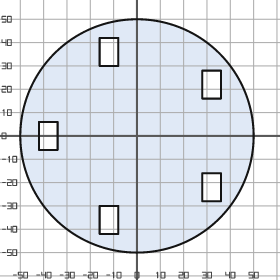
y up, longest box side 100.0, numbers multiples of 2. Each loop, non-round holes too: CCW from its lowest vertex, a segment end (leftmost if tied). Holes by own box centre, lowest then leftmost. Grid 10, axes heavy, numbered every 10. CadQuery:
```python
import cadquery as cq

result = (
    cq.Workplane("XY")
    .moveTo(0.0, 0.0)
    .circle(50.0)
    .moveTo(-16.0, -42.0)
    .lineTo(-8.0, -42.0)
    .lineTo(-8.0, -30.0)
    .lineTo(-16.0, -30.0)
    .close()
    .moveTo(28.0, -28.0)
    .lineTo(36.0, -28.0)
    .lineTo(36.0, -16.0)
    .lineTo(28.0, -16.0)
    .close()
    .moveTo(-42.0, -6.0)
    .lineTo(-34.0, -6.0)
    .lineTo(-34.0, 6.0)
    .lineTo(-42.0, 6.0)
    .close()
    .moveTo(28.0, 16.0)
    .lineTo(36.0, 16.0)
    .lineTo(36.0, 28.0)
    .lineTo(28.0, 28.0)
    .close()
    .moveTo(-16.0, 30.0)
    .lineTo(-8.0, 30.0)
    .lineTo(-8.0, 42.0)
    .lineTo(-16.0, 42.0)
    .close()
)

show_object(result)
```